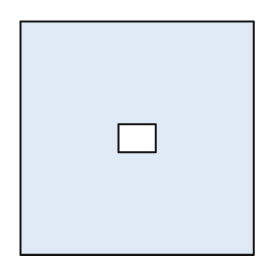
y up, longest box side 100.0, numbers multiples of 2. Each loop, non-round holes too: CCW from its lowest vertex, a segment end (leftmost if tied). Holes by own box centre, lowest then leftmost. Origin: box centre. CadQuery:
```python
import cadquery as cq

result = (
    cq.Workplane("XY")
    .moveTo(-50.0, -50.0)
    .lineTo(50.0, -50.0)
    .lineTo(50.0, 50.0)
    .lineTo(-50.0, 50.0)
    .close()
    .moveTo(-8.0, -6.0)
    .lineTo(8.0, -6.0)
    .lineTo(8.0, 6.0)
    .lineTo(-8.0, 6.0)
    .close()
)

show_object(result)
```